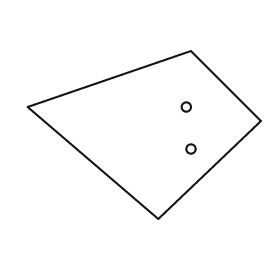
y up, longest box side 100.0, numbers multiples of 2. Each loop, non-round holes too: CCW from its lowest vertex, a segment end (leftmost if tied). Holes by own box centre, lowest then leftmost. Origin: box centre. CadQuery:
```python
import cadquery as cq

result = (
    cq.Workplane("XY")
    .moveTo(6.0, -36.0)
    .lineTo(50.0, 6.0)
    .lineTo(20.0, 36.0)
    .lineTo(-50.0, 12.0)
    .close()
    .moveTo(20.0, -6.0)
    .circle(2.0)
    .moveTo(18.0, 12.0)
    .circle(2.0)
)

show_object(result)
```